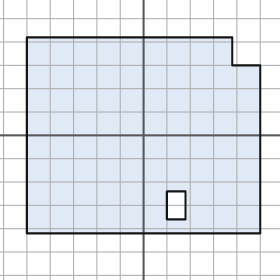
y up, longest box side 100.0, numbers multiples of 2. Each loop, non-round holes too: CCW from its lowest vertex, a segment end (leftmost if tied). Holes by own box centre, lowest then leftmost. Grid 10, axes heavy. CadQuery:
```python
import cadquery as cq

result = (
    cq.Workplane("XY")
    .moveTo(-50.0, -42.0)
    .lineTo(50.0, -42.0)
    .lineTo(50.0, 30.0)
    .lineTo(38.0, 30.0)
    .lineTo(38.0, 42.0)
    .lineTo(-50.0, 42.0)
    .close()
    .moveTo(10.0, -36.0)
    .lineTo(18.0, -36.0)
    .lineTo(18.0, -24.0)
    .lineTo(10.0, -24.0)
    .close()
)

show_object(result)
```